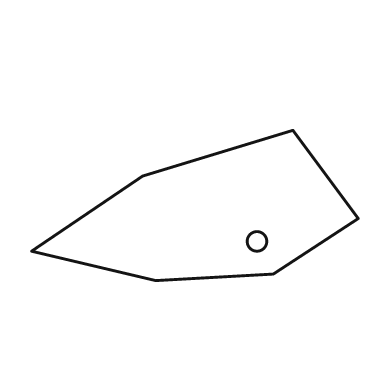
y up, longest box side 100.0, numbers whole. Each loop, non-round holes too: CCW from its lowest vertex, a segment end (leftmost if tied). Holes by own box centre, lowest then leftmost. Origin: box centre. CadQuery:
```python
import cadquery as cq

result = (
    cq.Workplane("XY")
    .moveTo(-12.0, -23.0)
    .lineTo(24.0, -21.0)
    .lineTo(50.0, -4.0)
    .lineTo(30.0, 23.0)
    .lineTo(-16.0, 9.0)
    .lineTo(-50.0, -14.0)
    .close()
    .moveTo(19.0, -11.0)
    .circle(3.0)
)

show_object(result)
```